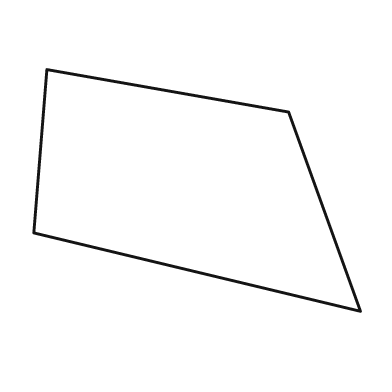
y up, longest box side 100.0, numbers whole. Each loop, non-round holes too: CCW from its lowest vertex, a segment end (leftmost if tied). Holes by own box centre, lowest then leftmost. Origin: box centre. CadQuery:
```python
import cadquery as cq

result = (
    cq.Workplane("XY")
    .moveTo(50.0, -37.0)
    .lineTo(28.0, 24.0)
    .lineTo(-46.0, 37.0)
    .lineTo(-50.0, -13.0)
    .close()
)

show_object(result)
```